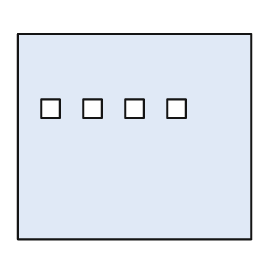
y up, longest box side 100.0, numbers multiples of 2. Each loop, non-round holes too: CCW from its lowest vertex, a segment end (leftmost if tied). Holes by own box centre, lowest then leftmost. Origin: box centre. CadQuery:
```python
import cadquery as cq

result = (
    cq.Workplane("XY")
    .moveTo(-50.0, -44.0)
    .lineTo(50.0, -44.0)
    .lineTo(50.0, 44.0)
    .lineTo(-50.0, 44.0)
    .close()
    .moveTo(-40.0, 8.0)
    .lineTo(-32.0, 8.0)
    .lineTo(-32.0, 16.0)
    .lineTo(-40.0, 16.0)
    .close()
    .moveTo(-22.0, 8.0)
    .lineTo(-14.0, 8.0)
    .lineTo(-14.0, 16.0)
    .lineTo(-22.0, 16.0)
    .close()
    .moveTo(-4.0, 8.0)
    .lineTo(4.0, 8.0)
    .lineTo(4.0, 16.0)
    .lineTo(-4.0, 16.0)
    .close()
    .moveTo(14.0, 8.0)
    .lineTo(22.0, 8.0)
    .lineTo(22.0, 16.0)
    .lineTo(14.0, 16.0)
    .close()
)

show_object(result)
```